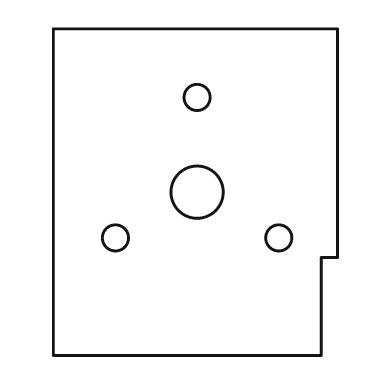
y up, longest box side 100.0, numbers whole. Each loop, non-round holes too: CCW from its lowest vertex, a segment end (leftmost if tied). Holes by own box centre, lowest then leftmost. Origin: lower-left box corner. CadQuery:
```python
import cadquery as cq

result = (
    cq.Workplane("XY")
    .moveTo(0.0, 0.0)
    .lineTo(82.0, 0.0)
    .lineTo(82.0, 30.0)
    .lineTo(87.0, 30.0)
    .lineTo(87.0, 100.0)
    .lineTo(0.0, 100.0)
    .close()
    .moveTo(19.0, 36.0)
    .circle(4.0)
    .moveTo(69.0, 36.0)
    .circle(4.0)
    .moveTo(44.0, 50.0)
    .circle(8.0)
    .moveTo(44.0, 79.0)
    .circle(4.0)
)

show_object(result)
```